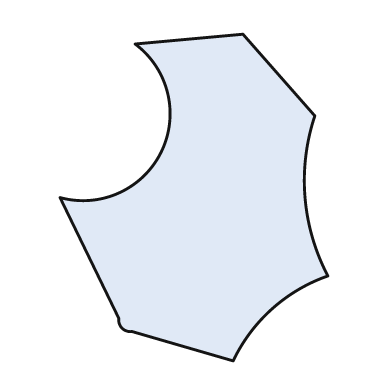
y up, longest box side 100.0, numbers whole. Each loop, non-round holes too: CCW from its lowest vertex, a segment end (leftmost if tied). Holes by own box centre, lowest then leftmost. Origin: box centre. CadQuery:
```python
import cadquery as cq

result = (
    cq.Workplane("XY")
    .moveTo(12.0, -50.0)
    .threePointArc((24.0, -34.0), (41.0, -24.0))
    .threePointArc((34.0, 0.0), (37.0, 25.0))
    .lineTo(15.0, 50.0)
    .lineTo(-18.0, 47.0)
    .threePointArc((-10.0, 14.0), (-41.0, 0.0))
    .lineTo(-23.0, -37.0)
    .threePointArc((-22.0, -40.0), (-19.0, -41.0))
    .close()
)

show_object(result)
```